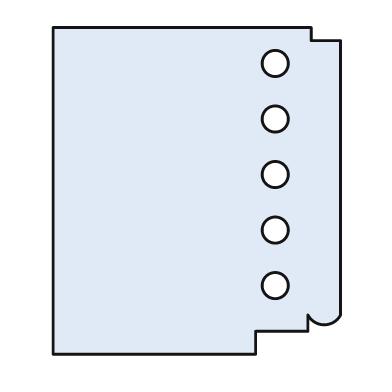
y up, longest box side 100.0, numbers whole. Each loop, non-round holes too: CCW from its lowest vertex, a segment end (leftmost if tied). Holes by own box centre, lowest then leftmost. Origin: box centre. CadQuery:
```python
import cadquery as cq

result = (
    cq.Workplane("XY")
    .moveTo(-44.0, -50.0)
    .lineTo(18.0, -50.0)
    .lineTo(18.0, -43.0)
    .lineTo(34.0, -43.0)
    .lineTo(34.0, -38.0)
    .threePointArc((39.0, -41.0), (44.0, -38.0))
    .lineTo(44.0, 46.0)
    .lineTo(35.0, 46.0)
    .lineTo(35.0, 50.0)
    .lineTo(-44.0, 50.0)
    .close()
    .moveTo(24.0, -29.0)
    .circle(4.0)
    .moveTo(24.0, -12.0)
    .circle(4.0)
    .moveTo(24.0, 5.0)
    .circle(4.0)
    .moveTo(24.0, 22.0)
    .circle(4.0)
    .moveTo(24.0, 39.0)
    .circle(4.0)
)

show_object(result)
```